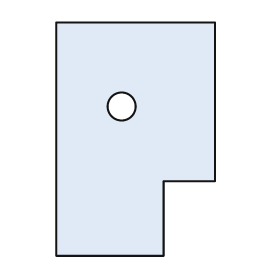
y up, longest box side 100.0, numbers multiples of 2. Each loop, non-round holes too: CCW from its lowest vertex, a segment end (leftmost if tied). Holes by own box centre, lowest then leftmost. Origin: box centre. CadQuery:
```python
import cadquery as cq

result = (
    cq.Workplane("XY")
    .moveTo(-34.0, -50.0)
    .lineTo(12.0, -50.0)
    .lineTo(12.0, -18.0)
    .lineTo(34.0, -18.0)
    .lineTo(34.0, 50.0)
    .lineTo(-34.0, 50.0)
    .close()
    .moveTo(-6.0, 14.0)
    .circle(6.0)
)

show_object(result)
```